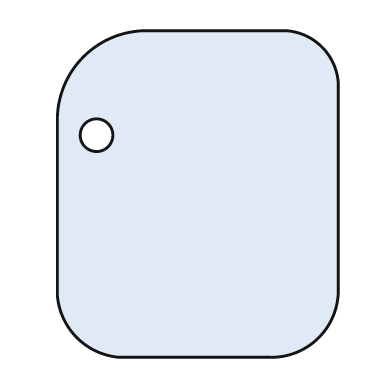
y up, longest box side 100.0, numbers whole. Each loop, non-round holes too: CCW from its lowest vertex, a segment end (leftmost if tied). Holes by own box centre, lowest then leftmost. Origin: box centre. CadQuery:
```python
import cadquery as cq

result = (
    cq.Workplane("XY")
    .moveTo(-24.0, -50.0)
    .lineTo(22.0, -50.0)
    .threePointArc((37.0, -44.0), (43.0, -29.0))
    .lineTo(43.0, 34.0)
    .threePointArc((38.0, 45.0), (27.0, 50.0))
    .lineTo(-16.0, 50.0)
    .threePointArc((-35.0, 42.0), (-43.0, 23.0))
    .lineTo(-43.0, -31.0)
    .threePointArc((-37.0, -44.0), (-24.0, -50.0))
    .close()
    .moveTo(-31.0, 18.0)
    .circle(5.0)
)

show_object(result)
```